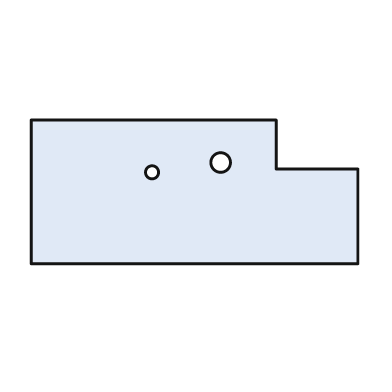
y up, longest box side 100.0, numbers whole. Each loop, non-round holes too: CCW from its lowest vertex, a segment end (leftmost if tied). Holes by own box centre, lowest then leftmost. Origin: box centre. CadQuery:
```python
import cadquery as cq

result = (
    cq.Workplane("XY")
    .moveTo(-50.0, -22.0)
    .lineTo(50.0, -22.0)
    .lineTo(50.0, 7.0)
    .lineTo(25.0, 7.0)
    .lineTo(25.0, 22.0)
    .lineTo(-50.0, 22.0)
    .close()
    .moveTo(-13.0, 6.0)
    .circle(2.0)
    .moveTo(8.0, 9.0)
    .circle(3.0)
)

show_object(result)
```